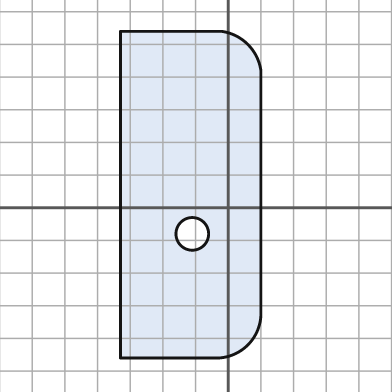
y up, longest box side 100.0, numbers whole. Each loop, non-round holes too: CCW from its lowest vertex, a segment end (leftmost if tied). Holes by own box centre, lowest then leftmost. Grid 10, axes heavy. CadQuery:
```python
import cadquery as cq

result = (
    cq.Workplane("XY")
    .moveTo(-33.0, -46.0)
    .lineTo(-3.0, -46.0)
    .threePointArc((6.0, -42.0), (10.0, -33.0))
    .lineTo(10.0, 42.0)
    .threePointArc((6.0, 50.0), (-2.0, 54.0))
    .lineTo(-33.0, 54.0)
    .close()
    .moveTo(-11.0, -8.0)
    .circle(5.0)
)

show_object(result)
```